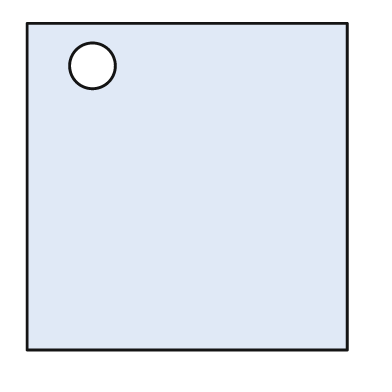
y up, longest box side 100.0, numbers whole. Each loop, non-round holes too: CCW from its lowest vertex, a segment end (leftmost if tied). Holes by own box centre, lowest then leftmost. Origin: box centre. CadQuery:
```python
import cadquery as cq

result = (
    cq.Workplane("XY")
    .moveTo(-49.0, -50.0)
    .lineTo(49.0, -50.0)
    .lineTo(49.0, 50.0)
    .lineTo(-49.0, 50.0)
    .close()
    .moveTo(-29.0, 37.0)
    .circle(7.0)
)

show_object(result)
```